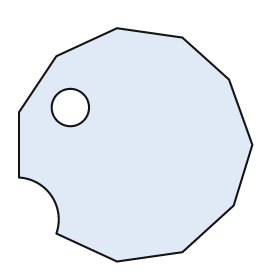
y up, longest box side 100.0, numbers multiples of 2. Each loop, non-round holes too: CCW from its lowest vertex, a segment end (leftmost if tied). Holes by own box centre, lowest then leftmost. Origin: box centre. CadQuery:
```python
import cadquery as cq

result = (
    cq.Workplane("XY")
    .moveTo(-8.0, -50.0)
    .lineTo(20.0, -46.0)
    .lineTo(42.0, -26.0)
    .lineTo(50.0, 0.0)
    .lineTo(40.0, 28.0)
    .lineTo(20.0, 46.0)
    .lineTo(-8.0, 50.0)
    .lineTo(-34.0, 38.0)
    .lineTo(-50.0, 14.0)
    .lineTo(-50.0, -14.0)
    .threePointArc((-36.0, -22.0), (-34.0, -38.0))
    .close()
    .moveTo(-28.0, 16.0)
    .circle(8.0)
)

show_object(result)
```